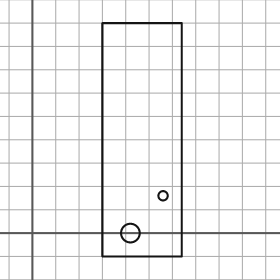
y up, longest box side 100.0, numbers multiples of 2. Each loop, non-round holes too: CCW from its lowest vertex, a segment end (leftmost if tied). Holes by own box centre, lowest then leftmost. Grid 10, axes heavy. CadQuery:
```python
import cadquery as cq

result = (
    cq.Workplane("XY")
    .moveTo(30.0, -10.0)
    .lineTo(64.0, -10.0)
    .lineTo(64.0, 90.0)
    .lineTo(30.0, 90.0)
    .close()
    .moveTo(42.0, 0.0)
    .circle(4.0)
    .moveTo(56.0, 16.0)
    .circle(2.0)
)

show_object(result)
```